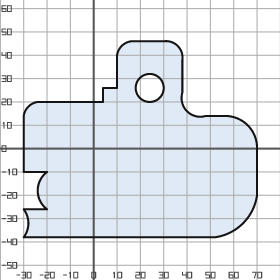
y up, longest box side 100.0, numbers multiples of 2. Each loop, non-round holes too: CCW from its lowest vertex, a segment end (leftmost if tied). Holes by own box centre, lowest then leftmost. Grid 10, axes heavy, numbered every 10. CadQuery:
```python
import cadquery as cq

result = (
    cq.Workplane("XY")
    .moveTo(-30.0, -38.0)
    .lineTo(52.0, -38.0)
    .threePointArc((64.0, -32.0), (70.0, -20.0))
    .lineTo(70.0, 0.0)
    .threePointArc((66.0, 10.0), (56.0, 14.0))
    .lineTo(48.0, 14.0)
    .threePointArc((40.0, 16.0), (38.0, 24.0))
    .lineTo(38.0, 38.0)
    .threePointArc((36.0, 44.0), (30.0, 46.0))
    .lineTo(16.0, 46.0)
    .threePointArc((12.0, 44.0), (10.0, 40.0))
    .lineTo(10.0, 26.0)
    .lineTo(4.0, 26.0)
    .lineTo(4.0, 20.0)
    .lineTo(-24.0, 20.0)
    .threePointArc((-28.0, 18.0), (-30.0, 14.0))
    .lineTo(-30.0, -10.0)
    .lineTo(-20.0, -10.0)
    .threePointArc((-24.0, -18.0), (-20.0, -26.0))
    .lineTo(-30.0, -26.0)
    .threePointArc((-28.0, -32.0), (-30.0, -38.0))
    .close()
    .moveTo(24.0, 26.0)
    .circle(6.0)
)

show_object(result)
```